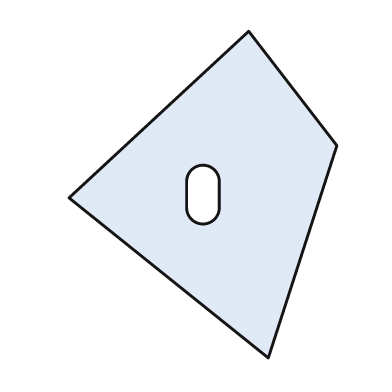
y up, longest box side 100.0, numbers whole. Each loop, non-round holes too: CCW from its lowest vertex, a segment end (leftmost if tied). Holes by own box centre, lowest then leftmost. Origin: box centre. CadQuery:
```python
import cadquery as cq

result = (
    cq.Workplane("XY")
    .moveTo(20.0, -50.0)
    .lineTo(41.0, 15.0)
    .lineTo(14.0, 50.0)
    .lineTo(-41.0, -1.0)
    .close()
    .moveTo(-5.0, -4.0)
    .threePointArc((0.0, -9.0), (5.0, -4.0))
    .lineTo(5.0, 4.0)
    .threePointArc((0.0, 9.0), (-5.0, 4.0))
    .close()
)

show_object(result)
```